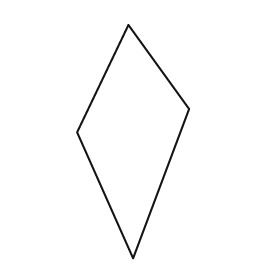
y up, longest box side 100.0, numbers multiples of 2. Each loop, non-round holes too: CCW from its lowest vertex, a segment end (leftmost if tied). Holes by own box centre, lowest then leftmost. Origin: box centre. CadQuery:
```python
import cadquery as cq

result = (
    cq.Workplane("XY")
    .moveTo(0.0, -50.0)
    .lineTo(24.0, 14.0)
    .lineTo(-2.0, 50.0)
    .lineTo(-24.0, 4.0)
    .close()
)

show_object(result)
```